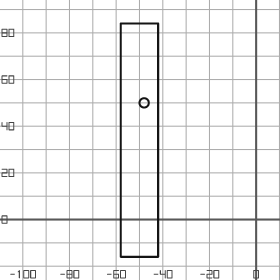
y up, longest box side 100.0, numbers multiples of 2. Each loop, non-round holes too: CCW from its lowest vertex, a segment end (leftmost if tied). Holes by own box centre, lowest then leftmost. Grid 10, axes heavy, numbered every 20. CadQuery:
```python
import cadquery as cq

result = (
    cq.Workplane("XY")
    .moveTo(-58.0, -16.0)
    .lineTo(-42.0, -16.0)
    .lineTo(-42.0, 84.0)
    .lineTo(-58.0, 84.0)
    .close()
    .moveTo(-48.0, 50.0)
    .circle(2.0)
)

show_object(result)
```